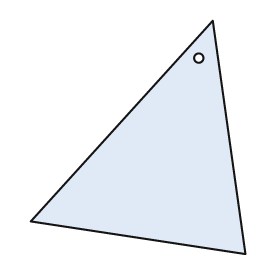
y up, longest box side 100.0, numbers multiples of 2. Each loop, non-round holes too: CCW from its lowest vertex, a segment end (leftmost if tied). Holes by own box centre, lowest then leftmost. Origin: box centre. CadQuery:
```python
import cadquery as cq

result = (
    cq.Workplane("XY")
    .moveTo(46.0, -50.0)
    .lineTo(32.0, 50.0)
    .lineTo(-46.0, -36.0)
    .close()
    .moveTo(26.0, 34.0)
    .circle(2.0)
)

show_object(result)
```